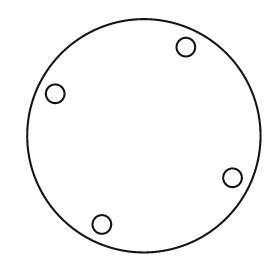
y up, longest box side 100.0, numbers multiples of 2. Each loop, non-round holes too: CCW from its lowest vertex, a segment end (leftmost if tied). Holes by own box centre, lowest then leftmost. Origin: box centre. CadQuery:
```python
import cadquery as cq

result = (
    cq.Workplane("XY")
    .moveTo(0.0, 0.0)
    .circle(50.0)
    .moveTo(-18.0, -38.0)
    .circle(4.0)
    .moveTo(38.0, -18.0)
    .circle(4.0)
    .moveTo(-38.0, 18.0)
    .circle(4.0)
    .moveTo(18.0, 38.0)
    .circle(4.0)
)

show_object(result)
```